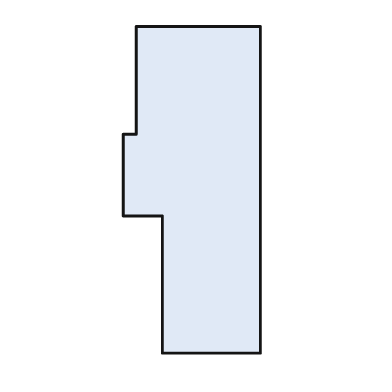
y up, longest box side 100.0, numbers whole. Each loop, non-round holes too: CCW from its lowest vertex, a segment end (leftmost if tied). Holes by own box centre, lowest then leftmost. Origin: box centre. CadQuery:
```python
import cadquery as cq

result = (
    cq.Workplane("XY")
    .moveTo(-9.0, -50.0)
    .lineTo(21.0, -50.0)
    .lineTo(21.0, 50.0)
    .lineTo(-17.0, 50.0)
    .lineTo(-17.0, 17.0)
    .lineTo(-21.0, 17.0)
    .lineTo(-21.0, -8.0)
    .lineTo(-9.0, -8.0)
    .close()
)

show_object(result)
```